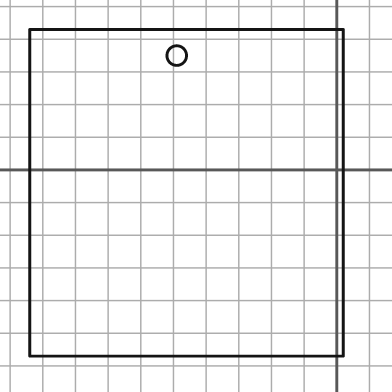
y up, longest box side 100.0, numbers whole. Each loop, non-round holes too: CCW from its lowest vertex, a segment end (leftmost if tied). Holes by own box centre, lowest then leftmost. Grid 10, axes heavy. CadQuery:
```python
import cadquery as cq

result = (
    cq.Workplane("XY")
    .moveTo(-94.0, -57.0)
    .lineTo(2.0, -57.0)
    .lineTo(2.0, 43.0)
    .lineTo(-94.0, 43.0)
    .close()
    .moveTo(-49.0, 35.0)
    .circle(3.0)
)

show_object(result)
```